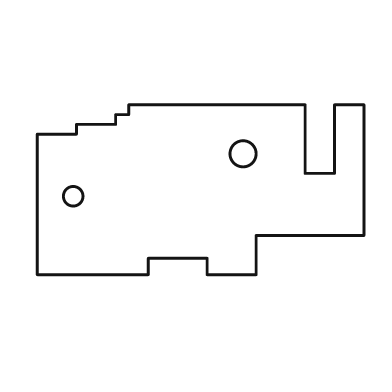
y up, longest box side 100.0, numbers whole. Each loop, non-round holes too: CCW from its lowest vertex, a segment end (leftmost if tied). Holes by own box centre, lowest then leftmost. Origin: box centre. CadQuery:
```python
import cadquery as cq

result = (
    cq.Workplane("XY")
    .moveTo(-50.0, -26.0)
    .lineTo(-16.0, -26.0)
    .lineTo(-16.0, -21.0)
    .lineTo(2.0, -21.0)
    .lineTo(2.0, -26.0)
    .lineTo(17.0, -26.0)
    .lineTo(17.0, -14.0)
    .lineTo(50.0, -14.0)
    .lineTo(50.0, 26.0)
    .lineTo(41.0, 26.0)
    .lineTo(41.0, 5.0)
    .lineTo(32.0, 5.0)
    .lineTo(32.0, 26.0)
    .lineTo(-22.0, 26.0)
    .lineTo(-22.0, 23.0)
    .lineTo(-26.0, 23.0)
    .lineTo(-26.0, 20.0)
    .lineTo(-38.0, 20.0)
    .lineTo(-38.0, 17.0)
    .lineTo(-50.0, 17.0)
    .close()
    .moveTo(-39.0, -2.0)
    .circle(3.0)
    .moveTo(13.0, 11.0)
    .circle(4.0)
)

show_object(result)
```